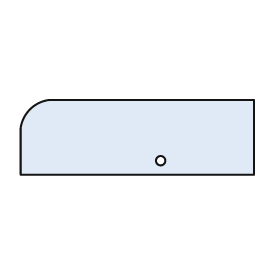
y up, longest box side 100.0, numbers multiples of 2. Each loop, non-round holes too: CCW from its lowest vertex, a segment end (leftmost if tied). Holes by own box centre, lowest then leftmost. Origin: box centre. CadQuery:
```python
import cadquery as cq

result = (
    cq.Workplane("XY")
    .moveTo(-50.0, -16.0)
    .lineTo(50.0, -16.0)
    .lineTo(50.0, 16.0)
    .lineTo(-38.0, 16.0)
    .threePointArc((-46.0, 12.0), (-50.0, 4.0))
    .close()
    .moveTo(10.0, -10.0)
    .circle(2.0)
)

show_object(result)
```